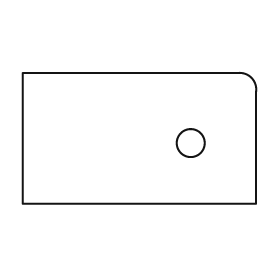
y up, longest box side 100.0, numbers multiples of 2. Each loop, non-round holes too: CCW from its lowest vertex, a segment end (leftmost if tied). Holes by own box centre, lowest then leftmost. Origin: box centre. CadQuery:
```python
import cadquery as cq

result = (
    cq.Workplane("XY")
    .moveTo(-50.0, -28.0)
    .lineTo(50.0, -28.0)
    .lineTo(50.0, 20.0)
    .threePointArc((48.0, 26.0), (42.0, 28.0))
    .lineTo(-50.0, 28.0)
    .close()
    .moveTo(22.0, -2.0)
    .circle(6.0)
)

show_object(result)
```